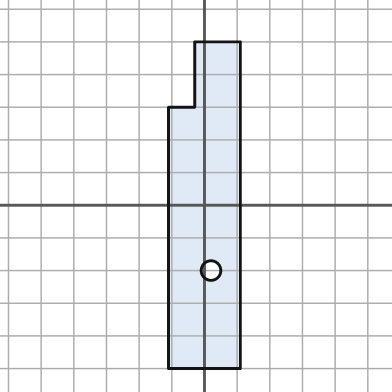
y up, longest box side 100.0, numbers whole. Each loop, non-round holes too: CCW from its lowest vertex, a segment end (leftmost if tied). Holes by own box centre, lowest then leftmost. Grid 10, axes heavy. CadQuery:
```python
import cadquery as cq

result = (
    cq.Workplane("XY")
    .moveTo(-11.0, -50.0)
    .lineTo(11.0, -50.0)
    .lineTo(11.0, 50.0)
    .lineTo(-3.0, 50.0)
    .lineTo(-3.0, 30.0)
    .lineTo(-11.0, 30.0)
    .close()
    .moveTo(2.0, -20.0)
    .circle(3.0)
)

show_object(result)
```